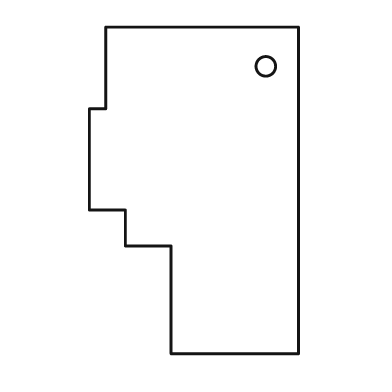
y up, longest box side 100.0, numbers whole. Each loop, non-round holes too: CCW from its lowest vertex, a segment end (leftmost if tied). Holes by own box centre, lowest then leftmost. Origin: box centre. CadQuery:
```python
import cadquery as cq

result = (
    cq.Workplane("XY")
    .moveTo(-7.0, -50.0)
    .lineTo(32.0, -50.0)
    .lineTo(32.0, 50.0)
    .lineTo(-27.0, 50.0)
    .lineTo(-27.0, 25.0)
    .lineTo(-32.0, 25.0)
    .lineTo(-32.0, -6.0)
    .lineTo(-21.0, -6.0)
    .lineTo(-21.0, -17.0)
    .lineTo(-7.0, -17.0)
    .close()
    .moveTo(22.0, 38.0)
    .circle(3.0)
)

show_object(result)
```